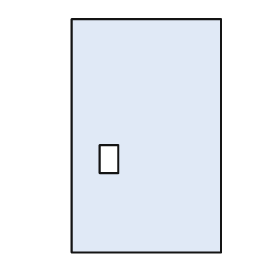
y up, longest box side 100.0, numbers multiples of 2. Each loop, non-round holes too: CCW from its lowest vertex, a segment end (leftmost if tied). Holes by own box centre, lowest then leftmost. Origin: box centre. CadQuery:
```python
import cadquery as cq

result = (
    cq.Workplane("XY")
    .moveTo(-32.0, -50.0)
    .lineTo(32.0, -50.0)
    .lineTo(32.0, 50.0)
    .lineTo(-32.0, 50.0)
    .close()
    .moveTo(-20.0, -16.0)
    .lineTo(-12.0, -16.0)
    .lineTo(-12.0, -4.0)
    .lineTo(-20.0, -4.0)
    .close()
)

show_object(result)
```